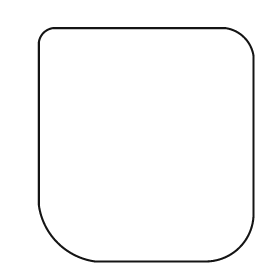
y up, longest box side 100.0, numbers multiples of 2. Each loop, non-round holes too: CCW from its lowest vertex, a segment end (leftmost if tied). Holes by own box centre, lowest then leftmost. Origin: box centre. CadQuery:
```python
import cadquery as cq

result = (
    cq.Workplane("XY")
    .moveTo(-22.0, -50.0)
    .lineTo(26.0, -50.0)
    .threePointArc((40.0, -44.0), (46.0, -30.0))
    .lineTo(46.0, 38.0)
    .threePointArc((42.0, 46.0), (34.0, 50.0))
    .lineTo(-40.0, 50.0)
    .threePointArc((-44.0, 48.0), (-46.0, 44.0))
    .lineTo(-46.0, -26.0)
    .threePointArc((-38.0, -42.0), (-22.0, -50.0))
    .close()
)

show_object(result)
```